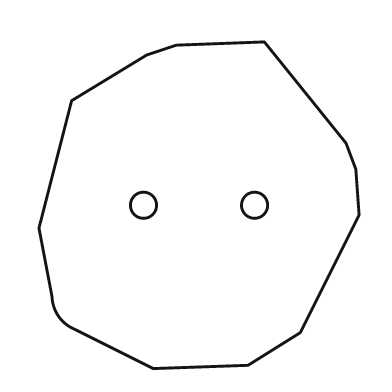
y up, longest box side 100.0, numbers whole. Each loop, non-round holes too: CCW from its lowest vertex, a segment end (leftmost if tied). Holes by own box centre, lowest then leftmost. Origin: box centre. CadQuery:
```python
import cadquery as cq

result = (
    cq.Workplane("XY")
    .moveTo(-14.0, -50.0)
    .lineTo(15.0, -49.0)
    .lineTo(31.0, -39.0)
    .lineTo(49.0, -3.0)
    .lineTo(48.0, 11.0)
    .lineTo(45.0, 19.0)
    .lineTo(20.0, 50.0)
    .lineTo(-7.0, 49.0)
    .lineTo(-16.0, 46.0)
    .lineTo(-39.0, 32.0)
    .lineTo(-49.0, -7.0)
    .lineTo(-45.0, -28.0)
    .threePointArc((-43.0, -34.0), (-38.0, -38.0))
    .close()
    .moveTo(-17.0, 0.0)
    .circle(4.0)
    .moveTo(17.0, 0.0)
    .circle(4.0)
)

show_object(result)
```